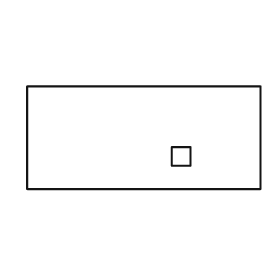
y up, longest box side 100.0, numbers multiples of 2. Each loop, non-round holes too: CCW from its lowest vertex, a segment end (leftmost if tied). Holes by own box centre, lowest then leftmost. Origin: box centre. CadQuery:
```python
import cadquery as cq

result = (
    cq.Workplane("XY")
    .moveTo(-50.0, -22.0)
    .lineTo(50.0, -22.0)
    .lineTo(50.0, 22.0)
    .lineTo(-50.0, 22.0)
    .close()
    .moveTo(12.0, -12.0)
    .lineTo(20.0, -12.0)
    .lineTo(20.0, -4.0)
    .lineTo(12.0, -4.0)
    .close()
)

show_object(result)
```